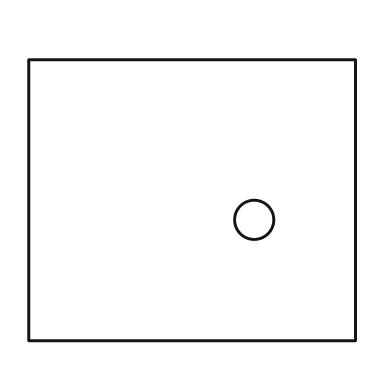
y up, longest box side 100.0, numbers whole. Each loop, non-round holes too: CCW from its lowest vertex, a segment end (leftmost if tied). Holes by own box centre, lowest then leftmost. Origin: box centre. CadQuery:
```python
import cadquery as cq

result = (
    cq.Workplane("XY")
    .moveTo(-50.0, -43.0)
    .lineTo(50.0, -43.0)
    .lineTo(50.0, 43.0)
    .lineTo(-50.0, 43.0)
    .close()
    .moveTo(19.0, -6.0)
    .circle(6.0)
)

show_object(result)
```